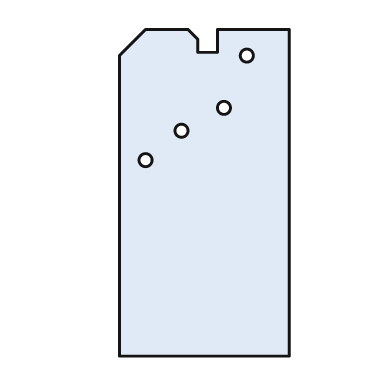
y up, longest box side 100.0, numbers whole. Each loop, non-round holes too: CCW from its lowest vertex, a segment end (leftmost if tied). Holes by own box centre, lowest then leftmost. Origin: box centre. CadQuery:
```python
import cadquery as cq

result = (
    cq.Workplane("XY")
    .moveTo(-26.0, -50.0)
    .lineTo(26.0, -50.0)
    .lineTo(26.0, 50.0)
    .lineTo(4.0, 50.0)
    .lineTo(4.0, 43.0)
    .lineTo(-2.0, 43.0)
    .lineTo(-2.0, 47.0)
    .lineTo(-5.0, 50.0)
    .lineTo(-18.0, 50.0)
    .lineTo(-26.0, 42.0)
    .close()
    .moveTo(-18.0, 10.0)
    .circle(2.0)
    .moveTo(-7.0, 19.0)
    .circle(2.0)
    .moveTo(6.0, 26.0)
    .circle(2.0)
    .moveTo(13.0, 42.0)
    .circle(2.0)
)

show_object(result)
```